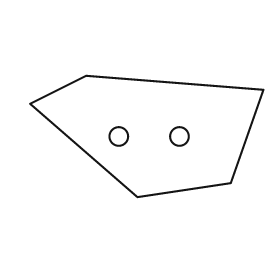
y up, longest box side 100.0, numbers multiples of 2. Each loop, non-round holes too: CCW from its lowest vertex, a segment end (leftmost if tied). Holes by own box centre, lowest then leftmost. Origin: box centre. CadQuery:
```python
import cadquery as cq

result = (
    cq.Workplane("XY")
    .moveTo(-4.0, -26.0)
    .lineTo(36.0, -20.0)
    .lineTo(50.0, 20.0)
    .lineTo(-26.0, 26.0)
    .lineTo(-50.0, 14.0)
    .close()
    .moveTo(-12.0, 0.0)
    .circle(4.0)
    .moveTo(14.0, 0.0)
    .circle(4.0)
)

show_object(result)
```